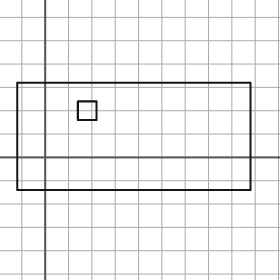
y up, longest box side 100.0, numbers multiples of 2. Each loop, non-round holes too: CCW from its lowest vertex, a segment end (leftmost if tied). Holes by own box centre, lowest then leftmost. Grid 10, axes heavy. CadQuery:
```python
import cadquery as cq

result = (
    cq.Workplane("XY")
    .moveTo(-12.0, -14.0)
    .lineTo(88.0, -14.0)
    .lineTo(88.0, 32.0)
    .lineTo(-12.0, 32.0)
    .close()
    .moveTo(14.0, 16.0)
    .lineTo(22.0, 16.0)
    .lineTo(22.0, 24.0)
    .lineTo(14.0, 24.0)
    .close()
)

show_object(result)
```